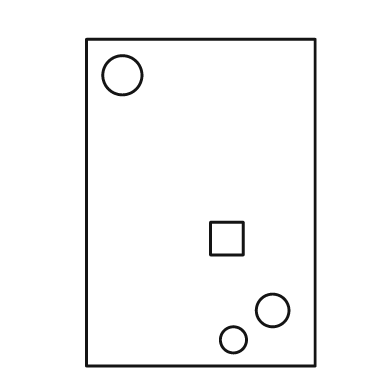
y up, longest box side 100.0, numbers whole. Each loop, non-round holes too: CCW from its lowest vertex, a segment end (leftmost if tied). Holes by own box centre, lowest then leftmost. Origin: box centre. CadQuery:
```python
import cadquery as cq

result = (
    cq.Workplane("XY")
    .moveTo(-35.0, -50.0)
    .lineTo(35.0, -50.0)
    .lineTo(35.0, 50.0)
    .lineTo(-35.0, 50.0)
    .close()
    .moveTo(10.0, -42.0)
    .circle(4.0)
    .moveTo(22.0, -33.0)
    .circle(5.0)
    .moveTo(3.0, -16.0)
    .lineTo(13.0, -16.0)
    .lineTo(13.0, -6.0)
    .lineTo(3.0, -6.0)
    .close()
    .moveTo(-24.0, 39.0)
    .circle(6.0)
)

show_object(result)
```